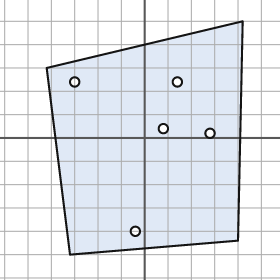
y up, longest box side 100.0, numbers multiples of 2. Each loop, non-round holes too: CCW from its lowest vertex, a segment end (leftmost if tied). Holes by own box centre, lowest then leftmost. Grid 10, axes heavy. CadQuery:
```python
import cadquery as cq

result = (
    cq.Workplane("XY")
    .moveTo(-32.0, -50.0)
    .lineTo(40.0, -44.0)
    .lineTo(42.0, 50.0)
    .lineTo(-42.0, 30.0)
    .close()
    .moveTo(-4.0, -40.0)
    .circle(2.0)
    .moveTo(28.0, 2.0)
    .circle(2.0)
    .moveTo(8.0, 4.0)
    .circle(2.0)
    .moveTo(-30.0, 24.0)
    .circle(2.0)
    .moveTo(14.0, 24.0)
    .circle(2.0)
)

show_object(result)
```